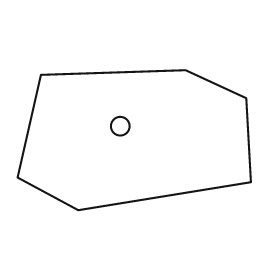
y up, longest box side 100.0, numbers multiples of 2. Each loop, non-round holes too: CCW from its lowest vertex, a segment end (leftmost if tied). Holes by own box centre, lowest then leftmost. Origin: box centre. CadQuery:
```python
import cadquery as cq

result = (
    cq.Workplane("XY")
    .moveTo(-24.0, -30.0)
    .lineTo(50.0, -18.0)
    .lineTo(48.0, 18.0)
    .lineTo(22.0, 30.0)
    .lineTo(-40.0, 28.0)
    .lineTo(-50.0, -16.0)
    .close()
    .moveTo(-6.0, 6.0)
    .circle(4.0)
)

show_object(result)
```